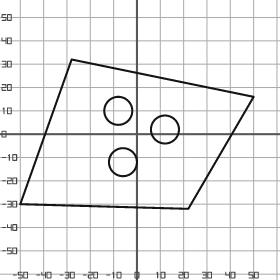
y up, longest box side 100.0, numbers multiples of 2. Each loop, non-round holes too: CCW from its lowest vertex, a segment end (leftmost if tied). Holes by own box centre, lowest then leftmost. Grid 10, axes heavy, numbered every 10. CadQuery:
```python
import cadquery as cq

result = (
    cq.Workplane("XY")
    .moveTo(22.0, -32.0)
    .lineTo(50.0, 16.0)
    .lineTo(-28.0, 32.0)
    .lineTo(-50.0, -30.0)
    .close()
    .moveTo(-6.0, -12.0)
    .circle(6.0)
    .moveTo(12.0, 2.0)
    .circle(6.0)
    .moveTo(-8.0, 10.0)
    .circle(6.0)
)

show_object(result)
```